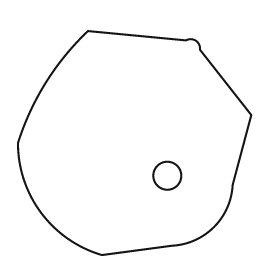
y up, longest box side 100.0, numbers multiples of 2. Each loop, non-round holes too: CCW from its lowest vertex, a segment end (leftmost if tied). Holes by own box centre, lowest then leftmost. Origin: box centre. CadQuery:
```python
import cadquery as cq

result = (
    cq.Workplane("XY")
    .moveTo(-14.0, -48.0)
    .lineTo(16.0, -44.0)
    .threePointArc((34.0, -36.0), (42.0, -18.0))
    .lineTo(50.0, 12.0)
    .lineTo(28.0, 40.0)
    .threePointArc((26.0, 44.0), (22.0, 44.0))
    .lineTo(-20.0, 48.0)
    .threePointArc((-38.0, 26.0), (-50.0, 0.0))
    .threePointArc((-40.0, -30.0), (-14.0, -48.0))
    .close()
    .moveTo(14.0, -14.0)
    .circle(6.0)
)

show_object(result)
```